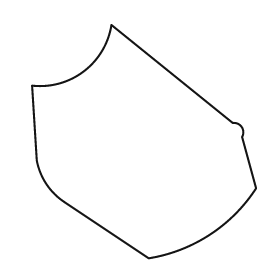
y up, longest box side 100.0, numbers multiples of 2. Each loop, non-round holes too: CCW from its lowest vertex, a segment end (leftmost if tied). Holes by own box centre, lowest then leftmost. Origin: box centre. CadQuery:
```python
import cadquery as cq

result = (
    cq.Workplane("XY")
    .moveTo(2.0, -50.0)
    .threePointArc((28.0, -40.0), (48.0, -20.0))
    .lineTo(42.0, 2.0)
    .threePointArc((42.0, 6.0), (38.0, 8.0))
    .lineTo(-14.0, 50.0)
    .threePointArc((-26.0, 30.0), (-48.0, 24.0))
    .lineTo(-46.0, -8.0)
    .threePointArc((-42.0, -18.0), (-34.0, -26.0))
    .close()
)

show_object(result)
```